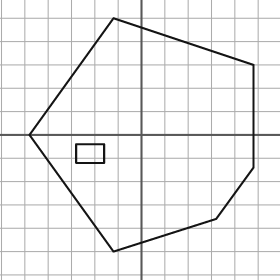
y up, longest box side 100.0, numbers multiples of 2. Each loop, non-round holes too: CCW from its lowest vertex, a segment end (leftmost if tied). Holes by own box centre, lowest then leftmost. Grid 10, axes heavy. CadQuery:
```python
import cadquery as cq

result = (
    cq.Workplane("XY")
    .moveTo(-12.0, -50.0)
    .lineTo(32.0, -36.0)
    .lineTo(48.0, -14.0)
    .lineTo(48.0, 30.0)
    .lineTo(-12.0, 50.0)
    .lineTo(-48.0, 0.0)
    .close()
    .moveTo(-28.0, -12.0)
    .lineTo(-16.0, -12.0)
    .lineTo(-16.0, -4.0)
    .lineTo(-28.0, -4.0)
    .close()
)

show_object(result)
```